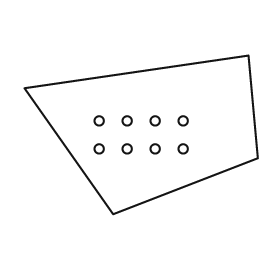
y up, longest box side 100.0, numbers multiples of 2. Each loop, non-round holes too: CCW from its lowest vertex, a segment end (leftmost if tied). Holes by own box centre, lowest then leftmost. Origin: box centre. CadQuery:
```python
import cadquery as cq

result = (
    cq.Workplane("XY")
    .moveTo(-12.0, -34.0)
    .lineTo(50.0, -10.0)
    .lineTo(46.0, 34.0)
    .lineTo(-50.0, 20.0)
    .close()
    .moveTo(-18.0, -6.0)
    .circle(2.0)
    .moveTo(-6.0, -6.0)
    .circle(2.0)
    .moveTo(6.0, -6.0)
    .circle(2.0)
    .moveTo(18.0, -6.0)
    .circle(2.0)
    .moveTo(-18.0, 6.0)
    .circle(2.0)
    .moveTo(-6.0, 6.0)
    .circle(2.0)
    .moveTo(6.0, 6.0)
    .circle(2.0)
    .moveTo(18.0, 6.0)
    .circle(2.0)
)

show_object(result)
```